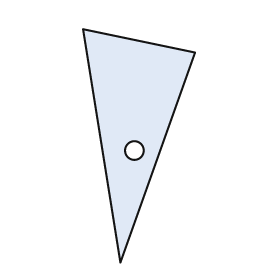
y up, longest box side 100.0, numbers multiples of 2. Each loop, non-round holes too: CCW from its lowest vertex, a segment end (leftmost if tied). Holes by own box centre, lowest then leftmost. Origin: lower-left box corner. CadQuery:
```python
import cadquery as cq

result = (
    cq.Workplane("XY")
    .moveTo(16.0, 0.0)
    .lineTo(48.0, 90.0)
    .lineTo(0.0, 100.0)
    .close()
    .moveTo(22.0, 48.0)
    .circle(4.0)
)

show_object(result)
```